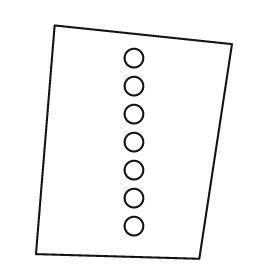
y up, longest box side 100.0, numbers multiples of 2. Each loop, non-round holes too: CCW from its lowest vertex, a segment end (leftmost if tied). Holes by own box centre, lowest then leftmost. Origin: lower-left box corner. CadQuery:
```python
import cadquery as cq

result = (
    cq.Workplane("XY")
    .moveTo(70.0, 0.0)
    .lineTo(84.0, 92.0)
    .lineTo(8.0, 100.0)
    .lineTo(0.0, 2.0)
    .close()
    .moveTo(42.0, 14.0)
    .circle(4.0)
    .moveTo(42.0, 26.0)
    .circle(4.0)
    .moveTo(42.0, 38.0)
    .circle(4.0)
    .moveTo(42.0, 50.0)
    .circle(4.0)
    .moveTo(42.0, 62.0)
    .circle(4.0)
    .moveTo(42.0, 74.0)
    .circle(4.0)
    .moveTo(42.0, 86.0)
    .circle(4.0)
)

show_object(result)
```